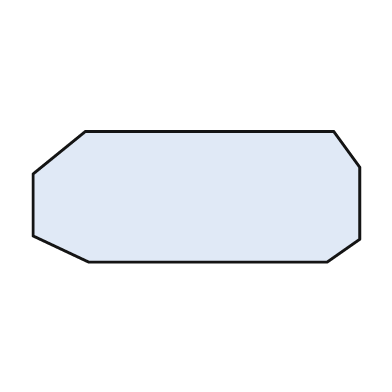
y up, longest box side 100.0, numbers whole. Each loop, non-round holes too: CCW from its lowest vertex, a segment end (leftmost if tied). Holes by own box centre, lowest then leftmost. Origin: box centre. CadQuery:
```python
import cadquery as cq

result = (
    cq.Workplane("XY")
    .moveTo(-33.0, -20.0)
    .lineTo(40.0, -20.0)
    .lineTo(50.0, -13.0)
    .lineTo(50.0, 9.0)
    .lineTo(42.0, 20.0)
    .lineTo(-34.0, 20.0)
    .lineTo(-50.0, 7.0)
    .lineTo(-50.0, -12.0)
    .close()
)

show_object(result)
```